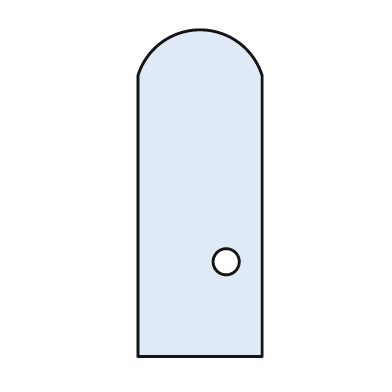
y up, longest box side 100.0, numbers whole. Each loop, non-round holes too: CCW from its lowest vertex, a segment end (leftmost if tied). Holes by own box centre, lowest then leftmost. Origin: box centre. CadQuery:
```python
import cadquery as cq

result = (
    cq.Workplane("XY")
    .moveTo(-19.0, -50.0)
    .lineTo(19.0, -50.0)
    .lineTo(19.0, 36.0)
    .threePointArc((0.0, 50.0), (-19.0, 36.0))
    .close()
    .moveTo(8.0, -21.0)
    .circle(4.0)
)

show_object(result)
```